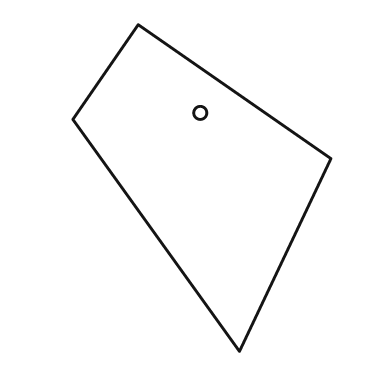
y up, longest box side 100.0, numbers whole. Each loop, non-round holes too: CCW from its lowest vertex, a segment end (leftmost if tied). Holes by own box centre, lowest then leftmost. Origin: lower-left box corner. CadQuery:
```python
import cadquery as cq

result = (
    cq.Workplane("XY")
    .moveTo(51.0, 0.0)
    .lineTo(79.0, 59.0)
    .lineTo(20.0, 100.0)
    .lineTo(0.0, 71.0)
    .close()
    .moveTo(39.0, 73.0)
    .circle(2.0)
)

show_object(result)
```